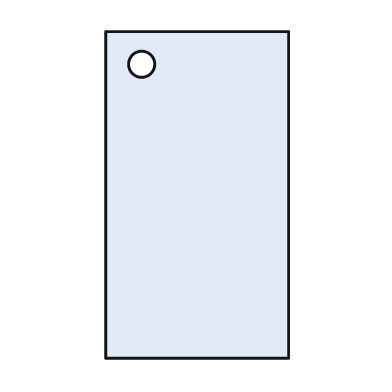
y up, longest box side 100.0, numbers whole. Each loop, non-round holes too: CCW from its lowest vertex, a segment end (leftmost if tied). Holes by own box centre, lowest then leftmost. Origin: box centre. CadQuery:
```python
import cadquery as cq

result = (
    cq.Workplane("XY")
    .moveTo(-28.0, -50.0)
    .lineTo(28.0, -50.0)
    .lineTo(28.0, 50.0)
    .lineTo(-28.0, 50.0)
    .close()
    .moveTo(-17.0, 40.0)
    .circle(4.0)
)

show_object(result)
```